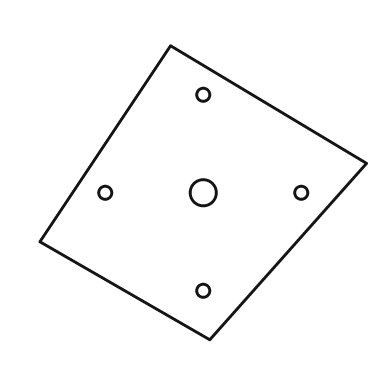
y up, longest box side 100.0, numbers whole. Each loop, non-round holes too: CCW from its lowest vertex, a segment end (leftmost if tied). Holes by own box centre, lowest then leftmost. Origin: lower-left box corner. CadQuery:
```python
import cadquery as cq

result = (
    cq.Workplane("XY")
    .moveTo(52.0, 0.0)
    .lineTo(100.0, 54.0)
    .lineTo(40.0, 90.0)
    .lineTo(0.0, 30.0)
    .close()
    .moveTo(50.0, 15.0)
    .circle(2.0)
    .moveTo(20.0, 45.0)
    .circle(2.0)
    .moveTo(50.0, 45.0)
    .circle(4.0)
    .moveTo(80.0, 45.0)
    .circle(2.0)
    .moveTo(50.0, 75.0)
    .circle(2.0)
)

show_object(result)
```